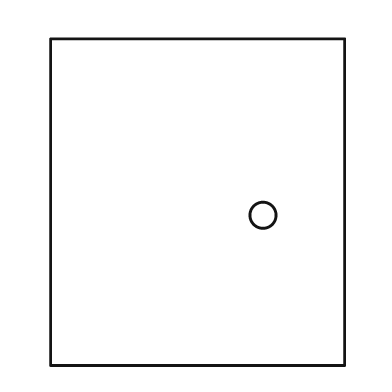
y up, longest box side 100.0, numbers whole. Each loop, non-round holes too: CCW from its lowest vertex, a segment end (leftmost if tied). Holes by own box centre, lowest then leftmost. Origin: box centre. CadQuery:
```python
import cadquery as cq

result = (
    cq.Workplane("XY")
    .moveTo(-45.0, -50.0)
    .lineTo(45.0, -50.0)
    .lineTo(45.0, 50.0)
    .lineTo(-45.0, 50.0)
    .close()
    .moveTo(20.0, -4.0)
    .circle(4.0)
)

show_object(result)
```